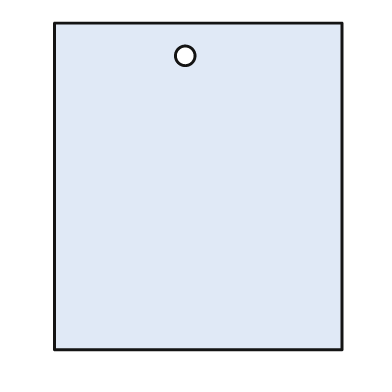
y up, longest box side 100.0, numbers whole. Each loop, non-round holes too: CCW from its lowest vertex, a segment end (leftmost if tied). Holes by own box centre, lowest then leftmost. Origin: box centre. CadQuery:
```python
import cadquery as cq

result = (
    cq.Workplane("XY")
    .moveTo(-44.0, -50.0)
    .lineTo(44.0, -50.0)
    .lineTo(44.0, 50.0)
    .lineTo(-44.0, 50.0)
    .close()
    .moveTo(-4.0, 40.0)
    .circle(3.0)
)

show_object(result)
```